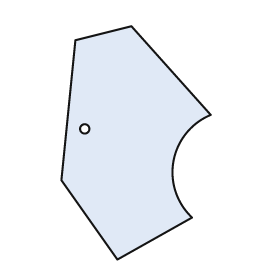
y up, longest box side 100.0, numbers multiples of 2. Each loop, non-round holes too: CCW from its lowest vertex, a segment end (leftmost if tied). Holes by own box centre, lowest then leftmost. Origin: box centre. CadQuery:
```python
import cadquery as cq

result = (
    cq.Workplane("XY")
    .moveTo(-8.0, -50.0)
    .lineTo(24.0, -32.0)
    .threePointArc((16.0, -8.0), (32.0, 12.0))
    .lineTo(-2.0, 50.0)
    .lineTo(-26.0, 44.0)
    .lineTo(-32.0, -16.0)
    .close()
    .moveTo(-22.0, 6.0)
    .circle(2.0)
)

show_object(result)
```